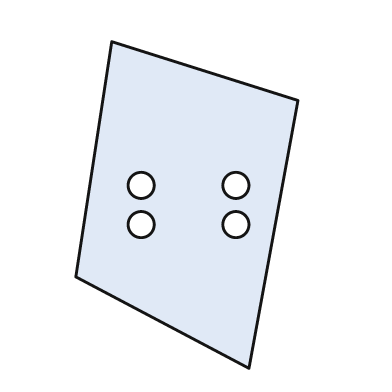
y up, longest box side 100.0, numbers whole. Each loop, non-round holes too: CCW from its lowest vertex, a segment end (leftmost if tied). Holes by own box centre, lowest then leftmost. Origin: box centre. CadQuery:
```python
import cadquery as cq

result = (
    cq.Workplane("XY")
    .moveTo(19.0, -50.0)
    .lineTo(34.0, 32.0)
    .lineTo(-23.0, 50.0)
    .lineTo(-34.0, -22.0)
    .close()
    .moveTo(-14.0, -6.0)
    .circle(4.0)
    .moveTo(15.0, -6.0)
    .circle(4.0)
    .moveTo(-14.0, 6.0)
    .circle(4.0)
    .moveTo(15.0, 6.0)
    .circle(4.0)
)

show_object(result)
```